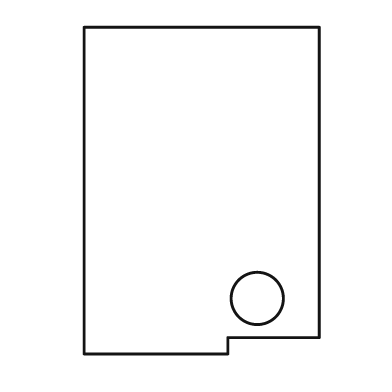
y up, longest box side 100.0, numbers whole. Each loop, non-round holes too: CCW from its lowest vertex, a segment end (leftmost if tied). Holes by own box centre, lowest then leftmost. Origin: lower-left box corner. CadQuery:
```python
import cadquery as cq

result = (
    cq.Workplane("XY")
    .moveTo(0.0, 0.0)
    .lineTo(44.0, 0.0)
    .lineTo(44.0, 5.0)
    .lineTo(72.0, 5.0)
    .lineTo(72.0, 100.0)
    .lineTo(0.0, 100.0)
    .close()
    .moveTo(53.0, 17.0)
    .circle(8.0)
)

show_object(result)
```